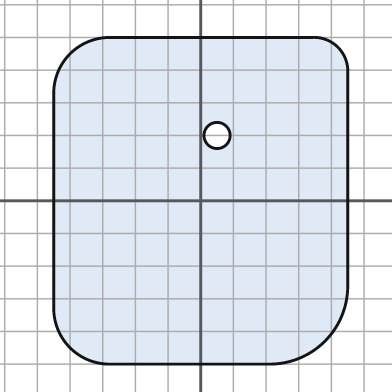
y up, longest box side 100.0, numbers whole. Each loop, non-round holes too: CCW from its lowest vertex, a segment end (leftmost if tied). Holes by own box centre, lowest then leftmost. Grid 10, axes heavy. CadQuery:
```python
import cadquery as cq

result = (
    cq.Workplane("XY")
    .moveTo(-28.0, -50.0)
    .lineTo(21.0, -50.0)
    .threePointArc((38.0, -43.0), (45.0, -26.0))
    .lineTo(45.0, 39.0)
    .threePointArc((42.0, 47.0), (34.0, 50.0))
    .lineTo(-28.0, 50.0)
    .threePointArc((-40.0, 45.0), (-45.0, 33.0))
    .lineTo(-45.0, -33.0)
    .threePointArc((-40.0, -45.0), (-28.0, -50.0))
    .close()
    .moveTo(5.0, 20.0)
    .circle(4.0)
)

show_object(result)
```